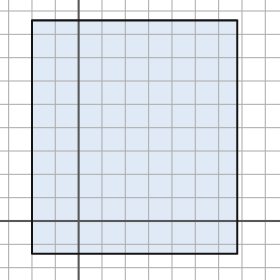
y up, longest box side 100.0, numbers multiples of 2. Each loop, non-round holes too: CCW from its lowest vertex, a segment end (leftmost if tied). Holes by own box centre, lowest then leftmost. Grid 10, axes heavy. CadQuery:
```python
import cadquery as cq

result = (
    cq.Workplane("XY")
    .moveTo(-20.0, -14.0)
    .lineTo(68.0, -14.0)
    .lineTo(68.0, 86.0)
    .lineTo(-20.0, 86.0)
    .close()
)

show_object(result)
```